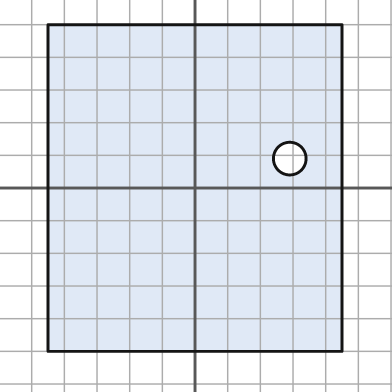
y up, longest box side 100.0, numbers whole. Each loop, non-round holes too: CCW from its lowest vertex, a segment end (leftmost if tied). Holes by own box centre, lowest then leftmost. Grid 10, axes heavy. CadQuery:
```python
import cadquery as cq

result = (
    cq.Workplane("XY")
    .moveTo(-45.0, -50.0)
    .lineTo(45.0, -50.0)
    .lineTo(45.0, 50.0)
    .lineTo(-45.0, 50.0)
    .close()
    .moveTo(29.0, 9.0)
    .circle(5.0)
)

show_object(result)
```